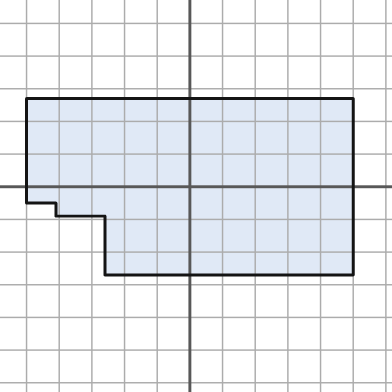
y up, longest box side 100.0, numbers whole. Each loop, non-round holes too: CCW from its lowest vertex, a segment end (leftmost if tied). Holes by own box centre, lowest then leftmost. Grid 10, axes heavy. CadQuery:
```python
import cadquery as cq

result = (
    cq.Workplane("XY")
    .moveTo(-26.0, -27.0)
    .lineTo(50.0, -27.0)
    .lineTo(50.0, 27.0)
    .lineTo(-50.0, 27.0)
    .lineTo(-50.0, -5.0)
    .lineTo(-41.0, -5.0)
    .lineTo(-41.0, -9.0)
    .lineTo(-26.0, -9.0)
    .close()
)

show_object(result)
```